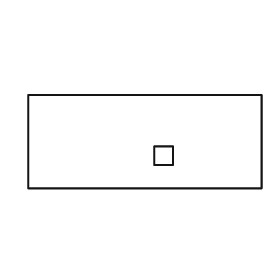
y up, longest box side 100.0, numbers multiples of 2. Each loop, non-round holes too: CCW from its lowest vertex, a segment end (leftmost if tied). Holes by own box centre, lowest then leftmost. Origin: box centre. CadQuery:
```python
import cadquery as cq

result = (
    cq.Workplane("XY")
    .moveTo(-50.0, -20.0)
    .lineTo(50.0, -20.0)
    .lineTo(50.0, 20.0)
    .lineTo(-50.0, 20.0)
    .close()
    .moveTo(4.0, -10.0)
    .lineTo(12.0, -10.0)
    .lineTo(12.0, -2.0)
    .lineTo(4.0, -2.0)
    .close()
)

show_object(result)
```